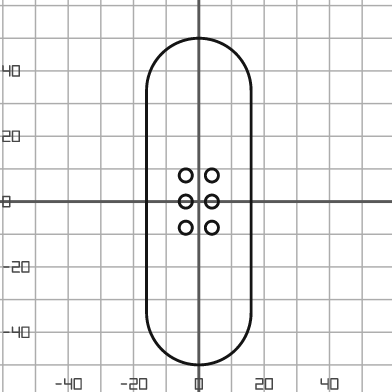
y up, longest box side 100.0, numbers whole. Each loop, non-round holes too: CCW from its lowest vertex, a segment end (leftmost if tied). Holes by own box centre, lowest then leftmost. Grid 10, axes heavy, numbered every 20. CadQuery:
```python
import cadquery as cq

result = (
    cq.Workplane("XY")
    .moveTo(-16.0, -34.0)
    .threePointArc((0.0, -50.0), (16.0, -34.0))
    .lineTo(16.0, 34.0)
    .threePointArc((0.0, 50.0), (-16.0, 34.0))
    .close()
    .moveTo(-4.0, -8.0)
    .circle(2.0)
    .moveTo(4.0, -8.0)
    .circle(2.0)
    .moveTo(-4.0, 0.0)
    .circle(2.0)
    .moveTo(4.0, 0.0)
    .circle(2.0)
    .moveTo(-4.0, 8.0)
    .circle(2.0)
    .moveTo(4.0, 8.0)
    .circle(2.0)
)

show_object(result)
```